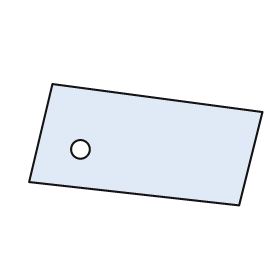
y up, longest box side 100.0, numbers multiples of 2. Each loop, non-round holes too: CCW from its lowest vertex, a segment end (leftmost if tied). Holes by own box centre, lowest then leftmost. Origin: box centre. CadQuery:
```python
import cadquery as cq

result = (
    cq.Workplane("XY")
    .moveTo(40.0, -26.0)
    .lineTo(50.0, 14.0)
    .lineTo(-40.0, 26.0)
    .lineTo(-50.0, -16.0)
    .close()
    .moveTo(-28.0, -2.0)
    .circle(4.0)
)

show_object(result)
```